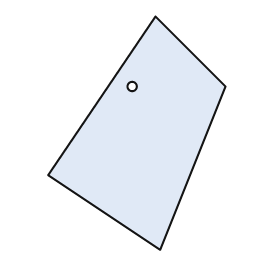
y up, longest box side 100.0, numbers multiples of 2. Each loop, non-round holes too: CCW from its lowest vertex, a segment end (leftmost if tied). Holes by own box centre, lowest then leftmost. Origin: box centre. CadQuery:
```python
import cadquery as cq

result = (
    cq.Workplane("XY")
    .moveTo(10.0, -50.0)
    .lineTo(38.0, 20.0)
    .lineTo(8.0, 50.0)
    .lineTo(-38.0, -18.0)
    .close()
    .moveTo(-2.0, 20.0)
    .circle(2.0)
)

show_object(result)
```